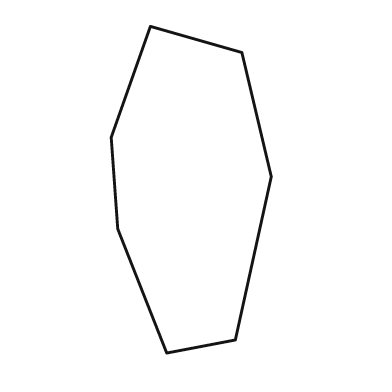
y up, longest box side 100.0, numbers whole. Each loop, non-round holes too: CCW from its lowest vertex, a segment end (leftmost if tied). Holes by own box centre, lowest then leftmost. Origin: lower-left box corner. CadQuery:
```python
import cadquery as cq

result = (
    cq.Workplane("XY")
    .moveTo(17.0, 0.0)
    .lineTo(38.0, 4.0)
    .lineTo(49.0, 54.0)
    .lineTo(40.0, 92.0)
    .lineTo(12.0, 100.0)
    .lineTo(0.0, 66.0)
    .lineTo(2.0, 38.0)
    .close()
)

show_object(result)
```